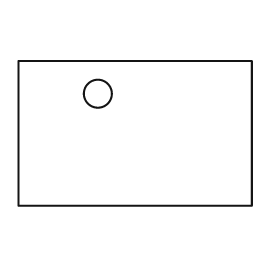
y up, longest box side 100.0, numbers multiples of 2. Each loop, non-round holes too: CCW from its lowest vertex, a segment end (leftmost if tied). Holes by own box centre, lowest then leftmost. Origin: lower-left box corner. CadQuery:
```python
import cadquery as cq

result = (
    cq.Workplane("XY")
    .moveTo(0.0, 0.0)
    .lineTo(100.0, 0.0)
    .lineTo(100.0, 62.0)
    .lineTo(0.0, 62.0)
    .close()
    .moveTo(34.0, 48.0)
    .circle(6.0)
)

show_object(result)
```